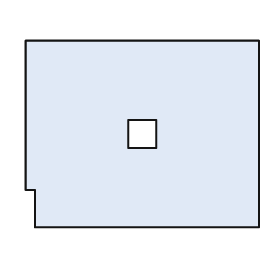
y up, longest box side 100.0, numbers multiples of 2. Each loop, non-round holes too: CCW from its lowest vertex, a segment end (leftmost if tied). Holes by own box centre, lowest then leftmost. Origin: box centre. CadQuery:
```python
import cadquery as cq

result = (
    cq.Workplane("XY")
    .moveTo(-46.0, -40.0)
    .lineTo(50.0, -40.0)
    .lineTo(50.0, 40.0)
    .lineTo(-50.0, 40.0)
    .lineTo(-50.0, -24.0)
    .lineTo(-46.0, -24.0)
    .close()
    .moveTo(-6.0, -6.0)
    .lineTo(6.0, -6.0)
    .lineTo(6.0, 6.0)
    .lineTo(-6.0, 6.0)
    .close()
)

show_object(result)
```